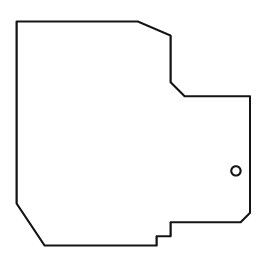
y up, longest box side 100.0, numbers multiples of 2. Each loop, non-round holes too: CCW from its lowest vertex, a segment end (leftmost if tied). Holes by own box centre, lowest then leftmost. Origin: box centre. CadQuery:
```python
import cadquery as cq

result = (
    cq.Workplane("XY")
    .moveTo(-38.0, -48.0)
    .lineTo(10.0, -48.0)
    .lineTo(10.0, -44.0)
    .lineTo(16.0, -44.0)
    .lineTo(16.0, -38.0)
    .lineTo(46.0, -38.0)
    .lineTo(50.0, -34.0)
    .lineTo(50.0, 16.0)
    .lineTo(22.0, 16.0)
    .lineTo(16.0, 22.0)
    .lineTo(16.0, 42.0)
    .lineTo(2.0, 48.0)
    .lineTo(-50.0, 48.0)
    .lineTo(-50.0, -30.0)
    .close()
    .moveTo(44.0, -16.0)
    .circle(2.0)
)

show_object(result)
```